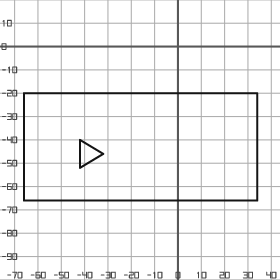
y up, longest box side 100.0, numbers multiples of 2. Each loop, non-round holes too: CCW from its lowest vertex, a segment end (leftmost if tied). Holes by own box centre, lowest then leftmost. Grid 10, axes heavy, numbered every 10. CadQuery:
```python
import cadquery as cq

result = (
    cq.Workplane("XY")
    .moveTo(-66.0, -66.0)
    .lineTo(34.0, -66.0)
    .lineTo(34.0, -20.0)
    .lineTo(-66.0, -20.0)
    .close()
    .moveTo(-42.0, -52.0)
    .lineTo(-32.0, -46.0)
    .lineTo(-42.0, -40.0)
    .close()
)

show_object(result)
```